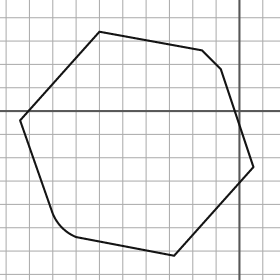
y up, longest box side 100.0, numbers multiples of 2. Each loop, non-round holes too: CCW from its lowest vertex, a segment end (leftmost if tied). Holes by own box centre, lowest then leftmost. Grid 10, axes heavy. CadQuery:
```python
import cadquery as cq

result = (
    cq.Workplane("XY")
    .moveTo(-28.0, -62.0)
    .lineTo(6.0, -24.0)
    .lineTo(-8.0, 18.0)
    .lineTo(-16.0, 26.0)
    .lineTo(-60.0, 34.0)
    .lineTo(-94.0, -4.0)
    .lineTo(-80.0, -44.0)
    .threePointArc((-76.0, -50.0), (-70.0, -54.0))
    .close()
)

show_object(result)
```